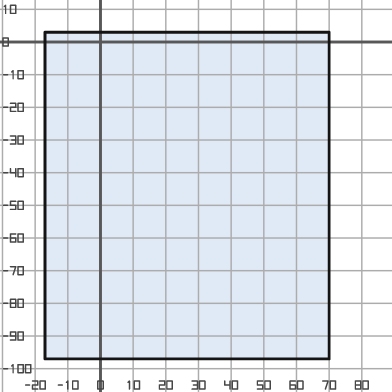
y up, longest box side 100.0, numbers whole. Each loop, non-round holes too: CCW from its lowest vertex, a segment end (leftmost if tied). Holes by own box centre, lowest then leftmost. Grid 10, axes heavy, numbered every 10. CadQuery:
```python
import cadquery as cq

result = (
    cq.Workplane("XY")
    .moveTo(-17.0, -97.0)
    .lineTo(70.0, -97.0)
    .lineTo(70.0, 3.0)
    .lineTo(-17.0, 3.0)
    .close()
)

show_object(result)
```